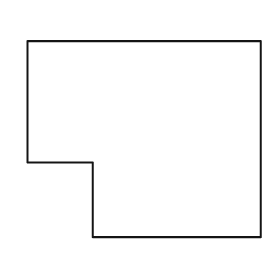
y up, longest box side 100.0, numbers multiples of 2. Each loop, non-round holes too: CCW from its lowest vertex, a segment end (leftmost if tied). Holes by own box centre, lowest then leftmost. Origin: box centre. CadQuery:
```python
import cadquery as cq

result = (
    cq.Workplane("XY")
    .moveTo(-22.0, -42.0)
    .lineTo(50.0, -42.0)
    .lineTo(50.0, 42.0)
    .lineTo(-50.0, 42.0)
    .lineTo(-50.0, -10.0)
    .lineTo(-22.0, -10.0)
    .close()
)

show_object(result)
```